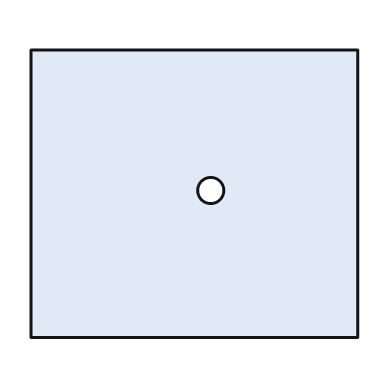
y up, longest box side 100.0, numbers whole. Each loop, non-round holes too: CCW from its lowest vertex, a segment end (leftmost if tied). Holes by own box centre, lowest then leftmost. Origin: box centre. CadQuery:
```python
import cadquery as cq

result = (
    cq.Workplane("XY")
    .moveTo(-50.0, -44.0)
    .lineTo(50.0, -44.0)
    .lineTo(50.0, 44.0)
    .lineTo(-50.0, 44.0)
    .close()
    .moveTo(5.0, 1.0)
    .circle(4.0)
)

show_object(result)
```